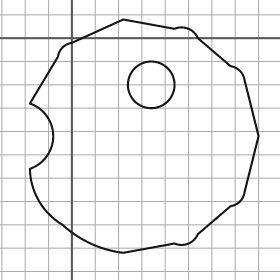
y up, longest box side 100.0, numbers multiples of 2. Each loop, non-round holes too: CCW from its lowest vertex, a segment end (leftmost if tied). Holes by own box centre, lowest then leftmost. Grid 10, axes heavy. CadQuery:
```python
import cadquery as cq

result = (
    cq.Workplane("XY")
    .moveTo(22.0, -92.0)
    .lineTo(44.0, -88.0)
    .threePointArc((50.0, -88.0), (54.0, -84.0))
    .lineTo(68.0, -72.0)
    .threePointArc((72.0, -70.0), (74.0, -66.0))
    .lineTo(80.0, -42.0)
    .lineTo(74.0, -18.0)
    .threePointArc((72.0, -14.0), (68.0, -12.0))
    .lineTo(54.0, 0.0)
    .threePointArc((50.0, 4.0), (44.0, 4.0))
    .lineTo(22.0, 8.0)
    .lineTo(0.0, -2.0)
    .threePointArc((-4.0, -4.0), (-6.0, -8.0))
    .lineTo(-18.0, -28.0)
    .threePointArc((-8.0, -42.0), (-18.0, -56.0))
    .threePointArc((-14.0, -70.0), (-4.0, -80.0))
    .threePointArc((8.0, -88.0), (22.0, -92.0))
    .close()
    .moveTo(34.0, -20.0)
    .circle(10.0)
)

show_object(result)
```